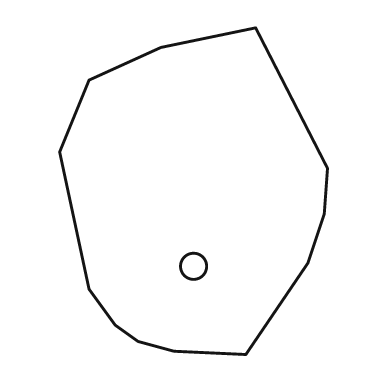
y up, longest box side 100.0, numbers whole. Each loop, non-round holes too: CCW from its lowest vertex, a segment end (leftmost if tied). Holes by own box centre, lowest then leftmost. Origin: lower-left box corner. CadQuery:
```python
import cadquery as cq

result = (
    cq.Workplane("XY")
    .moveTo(57.0, 0.0)
    .lineTo(76.0, 28.0)
    .lineTo(81.0, 43.0)
    .lineTo(82.0, 57.0)
    .lineTo(60.0, 100.0)
    .lineTo(31.0, 94.0)
    .lineTo(9.0, 84.0)
    .lineTo(0.0, 62.0)
    .lineTo(9.0, 20.0)
    .lineTo(17.0, 9.0)
    .lineTo(24.0, 4.0)
    .lineTo(35.0, 1.0)
    .close()
    .moveTo(41.0, 27.0)
    .circle(4.0)
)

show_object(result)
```